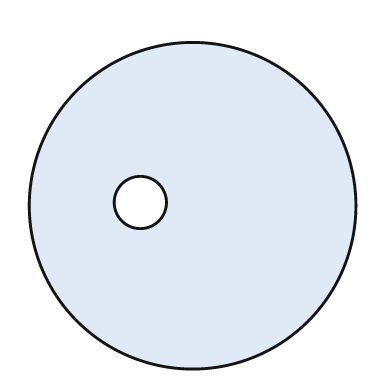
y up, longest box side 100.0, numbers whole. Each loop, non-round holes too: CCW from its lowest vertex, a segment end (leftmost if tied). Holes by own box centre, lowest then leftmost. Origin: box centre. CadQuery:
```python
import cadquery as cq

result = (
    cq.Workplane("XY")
    .moveTo(0.0, 0.0)
    .circle(50.0)
    .moveTo(-16.0, 1.0)
    .circle(8.0)
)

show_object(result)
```